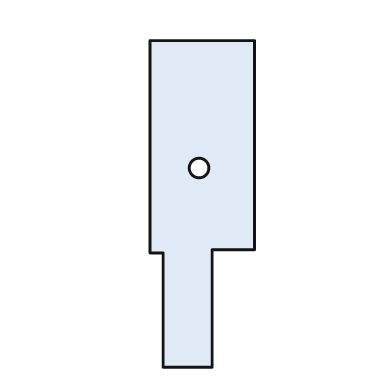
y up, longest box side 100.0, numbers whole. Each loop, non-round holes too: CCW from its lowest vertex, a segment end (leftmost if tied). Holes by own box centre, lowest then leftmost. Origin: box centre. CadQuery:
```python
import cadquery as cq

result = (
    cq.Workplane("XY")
    .moveTo(-12.0, -50.0)
    .lineTo(3.0, -50.0)
    .lineTo(3.0, -14.0)
    .lineTo(16.0, -14.0)
    .lineTo(16.0, 50.0)
    .lineTo(-16.0, 50.0)
    .lineTo(-16.0, -15.0)
    .lineTo(-12.0, -15.0)
    .close()
    .moveTo(-1.0, 11.0)
    .circle(3.0)
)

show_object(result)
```